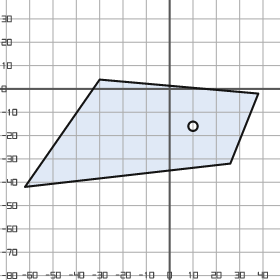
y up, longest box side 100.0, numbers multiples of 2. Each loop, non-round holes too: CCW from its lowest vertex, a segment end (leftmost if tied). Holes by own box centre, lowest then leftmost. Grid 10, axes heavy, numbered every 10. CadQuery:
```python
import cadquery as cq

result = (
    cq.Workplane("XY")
    .moveTo(-62.0, -42.0)
    .lineTo(26.0, -32.0)
    .lineTo(38.0, -2.0)
    .lineTo(-30.0, 4.0)
    .close()
    .moveTo(10.0, -16.0)
    .circle(2.0)
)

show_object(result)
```